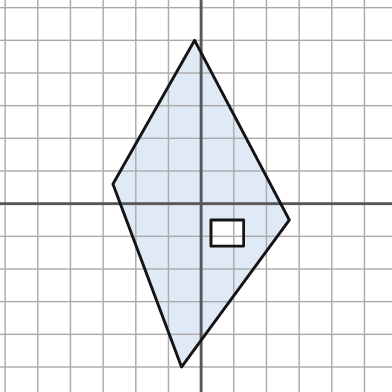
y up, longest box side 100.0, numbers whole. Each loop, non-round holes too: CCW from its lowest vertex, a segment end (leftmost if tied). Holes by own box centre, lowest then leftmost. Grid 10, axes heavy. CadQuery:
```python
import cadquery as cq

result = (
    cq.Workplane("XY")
    .moveTo(-6.0, -50.0)
    .lineTo(27.0, -5.0)
    .lineTo(-2.0, 50.0)
    .lineTo(-27.0, 6.0)
    .close()
    .moveTo(3.0, -13.0)
    .lineTo(13.0, -13.0)
    .lineTo(13.0, -5.0)
    .lineTo(3.0, -5.0)
    .close()
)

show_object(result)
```